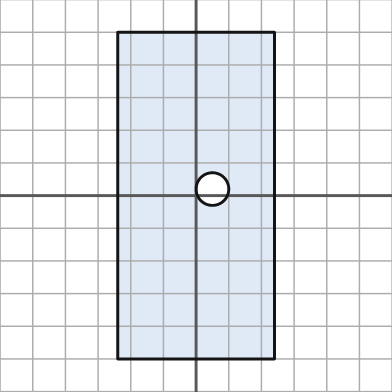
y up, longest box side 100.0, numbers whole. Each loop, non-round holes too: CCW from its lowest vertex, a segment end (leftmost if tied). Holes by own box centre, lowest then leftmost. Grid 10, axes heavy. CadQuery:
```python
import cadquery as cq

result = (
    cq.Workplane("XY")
    .moveTo(-24.0, -50.0)
    .lineTo(24.0, -50.0)
    .lineTo(24.0, 50.0)
    .lineTo(-24.0, 50.0)
    .close()
    .moveTo(5.0, 2.0)
    .circle(5.0)
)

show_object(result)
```